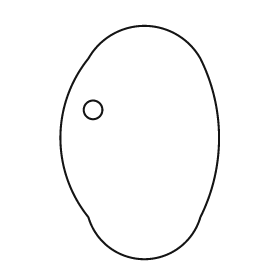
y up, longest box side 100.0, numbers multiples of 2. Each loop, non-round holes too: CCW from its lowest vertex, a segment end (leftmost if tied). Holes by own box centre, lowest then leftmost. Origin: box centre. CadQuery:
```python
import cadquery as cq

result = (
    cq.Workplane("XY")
    .moveTo(-22.0, -32.0)
    .threePointArc((2.0, -50.0), (26.0, -32.0))
    .threePointArc((34.0, 2.0), (26.0, 36.0))
    .threePointArc((2.0, 50.0), (-22.0, 36.0))
    .threePointArc((-34.0, 2.0), (-22.0, -32.0))
    .close()
    .moveTo(-20.0, 14.0)
    .circle(4.0)
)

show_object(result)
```